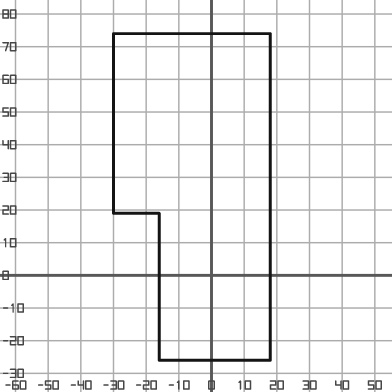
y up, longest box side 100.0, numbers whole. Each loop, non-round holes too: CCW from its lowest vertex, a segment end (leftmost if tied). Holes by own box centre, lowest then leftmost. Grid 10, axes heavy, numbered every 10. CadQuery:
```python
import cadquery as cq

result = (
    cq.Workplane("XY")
    .moveTo(-16.0, -26.0)
    .lineTo(18.0, -26.0)
    .lineTo(18.0, 74.0)
    .lineTo(-30.0, 74.0)
    .lineTo(-30.0, 19.0)
    .lineTo(-16.0, 19.0)
    .close()
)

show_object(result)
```